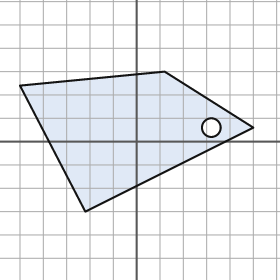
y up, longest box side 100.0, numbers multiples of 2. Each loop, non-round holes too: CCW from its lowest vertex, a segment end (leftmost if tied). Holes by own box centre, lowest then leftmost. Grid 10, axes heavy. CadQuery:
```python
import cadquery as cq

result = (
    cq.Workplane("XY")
    .moveTo(-22.0, -30.0)
    .lineTo(50.0, 6.0)
    .lineTo(12.0, 30.0)
    .lineTo(-50.0, 24.0)
    .close()
    .moveTo(32.0, 6.0)
    .circle(4.0)
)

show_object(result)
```